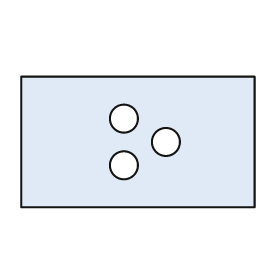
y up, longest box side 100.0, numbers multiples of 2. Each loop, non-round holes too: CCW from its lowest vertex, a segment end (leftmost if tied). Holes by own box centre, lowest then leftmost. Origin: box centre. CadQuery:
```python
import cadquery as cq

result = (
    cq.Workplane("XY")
    .moveTo(-50.0, -28.0)
    .lineTo(50.0, -28.0)
    .lineTo(50.0, 28.0)
    .lineTo(-50.0, 28.0)
    .close()
    .moveTo(-6.0, -10.0)
    .circle(6.0)
    .moveTo(12.0, 0.0)
    .circle(6.0)
    .moveTo(-6.0, 10.0)
    .circle(6.0)
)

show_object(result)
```